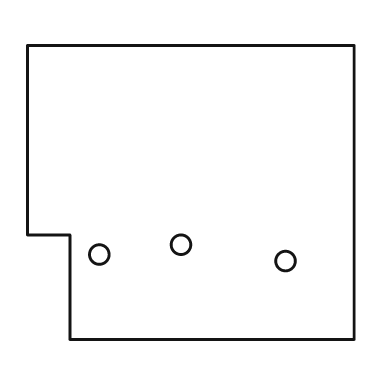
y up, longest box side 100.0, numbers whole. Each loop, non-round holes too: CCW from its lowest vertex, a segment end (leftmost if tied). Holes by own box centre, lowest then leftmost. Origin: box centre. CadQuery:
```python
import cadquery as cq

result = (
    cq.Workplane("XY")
    .moveTo(-37.0, -45.0)
    .lineTo(50.0, -45.0)
    .lineTo(50.0, 45.0)
    .lineTo(-50.0, 45.0)
    .lineTo(-50.0, -13.0)
    .lineTo(-37.0, -13.0)
    .close()
    .moveTo(29.0, -21.0)
    .circle(3.0)
    .moveTo(-28.0, -19.0)
    .circle(3.0)
    .moveTo(-3.0, -16.0)
    .circle(3.0)
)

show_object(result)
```